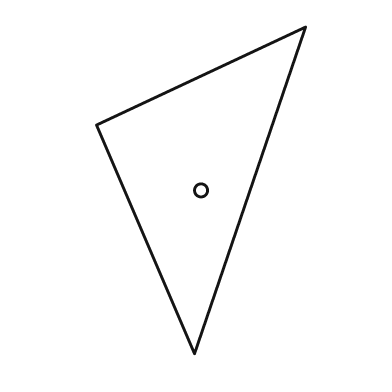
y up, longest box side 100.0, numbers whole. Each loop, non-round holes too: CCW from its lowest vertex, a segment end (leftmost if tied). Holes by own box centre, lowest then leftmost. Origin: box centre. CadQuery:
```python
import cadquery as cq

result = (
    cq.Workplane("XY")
    .moveTo(-2.0, -50.0)
    .lineTo(32.0, 50.0)
    .lineTo(-32.0, 20.0)
    .close()
    .moveTo(0.0, 0.0)
    .circle(2.0)
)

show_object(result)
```